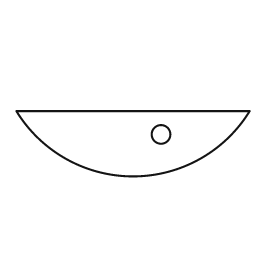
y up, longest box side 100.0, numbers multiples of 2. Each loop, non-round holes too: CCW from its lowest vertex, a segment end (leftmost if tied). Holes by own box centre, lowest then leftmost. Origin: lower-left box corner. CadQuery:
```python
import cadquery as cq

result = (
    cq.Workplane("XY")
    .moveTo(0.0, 28.0)
    .threePointArc((50.0, 0.0), (100.0, 28.0))
    .close()
    .moveTo(62.0, 18.0)
    .circle(4.0)
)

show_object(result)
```